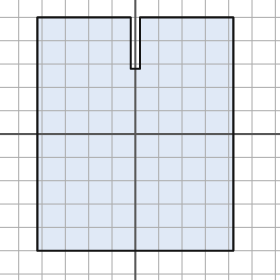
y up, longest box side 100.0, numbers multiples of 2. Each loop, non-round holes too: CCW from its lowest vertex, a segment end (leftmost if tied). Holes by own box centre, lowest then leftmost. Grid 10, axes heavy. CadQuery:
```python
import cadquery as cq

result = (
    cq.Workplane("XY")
    .moveTo(-42.0, -50.0)
    .lineTo(42.0, -50.0)
    .lineTo(42.0, 50.0)
    .lineTo(2.0, 50.0)
    .lineTo(2.0, 28.0)
    .lineTo(-2.0, 28.0)
    .lineTo(-2.0, 50.0)
    .lineTo(-42.0, 50.0)
    .close()
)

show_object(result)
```